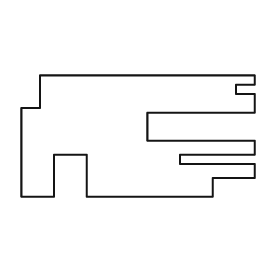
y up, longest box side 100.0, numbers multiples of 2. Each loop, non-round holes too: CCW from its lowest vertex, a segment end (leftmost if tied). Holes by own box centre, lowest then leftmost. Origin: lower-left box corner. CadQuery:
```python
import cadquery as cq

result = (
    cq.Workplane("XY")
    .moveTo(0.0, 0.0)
    .lineTo(14.0, 0.0)
    .lineTo(14.0, 18.0)
    .lineTo(28.0, 18.0)
    .lineTo(28.0, 0.0)
    .lineTo(82.0, 0.0)
    .lineTo(82.0, 8.0)
    .lineTo(100.0, 8.0)
    .lineTo(100.0, 14.0)
    .lineTo(68.0, 14.0)
    .lineTo(68.0, 18.0)
    .lineTo(100.0, 18.0)
    .lineTo(100.0, 24.0)
    .lineTo(54.0, 24.0)
    .lineTo(54.0, 36.0)
    .lineTo(100.0, 36.0)
    .lineTo(100.0, 44.0)
    .lineTo(92.0, 44.0)
    .lineTo(92.0, 48.0)
    .lineTo(100.0, 48.0)
    .lineTo(100.0, 52.0)
    .lineTo(8.0, 52.0)
    .lineTo(8.0, 38.0)
    .lineTo(0.0, 38.0)
    .close()
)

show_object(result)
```